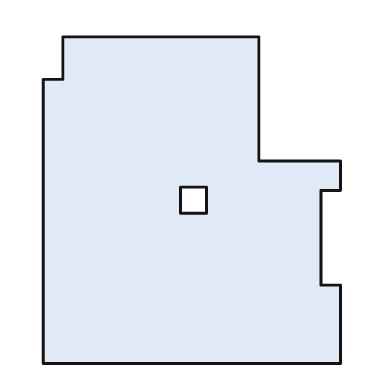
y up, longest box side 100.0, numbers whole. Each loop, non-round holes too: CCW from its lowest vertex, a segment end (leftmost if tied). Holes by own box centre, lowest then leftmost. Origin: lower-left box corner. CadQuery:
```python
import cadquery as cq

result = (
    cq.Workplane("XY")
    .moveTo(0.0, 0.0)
    .lineTo(91.0, 0.0)
    .lineTo(91.0, 24.0)
    .lineTo(85.0, 24.0)
    .lineTo(85.0, 53.0)
    .lineTo(91.0, 53.0)
    .lineTo(91.0, 62.0)
    .lineTo(66.0, 62.0)
    .lineTo(66.0, 100.0)
    .lineTo(6.0, 100.0)
    .lineTo(6.0, 87.0)
    .lineTo(0.0, 87.0)
    .close()
    .moveTo(42.0, 46.0)
    .lineTo(50.0, 46.0)
    .lineTo(50.0, 54.0)
    .lineTo(42.0, 54.0)
    .close()
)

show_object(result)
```